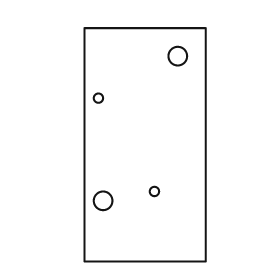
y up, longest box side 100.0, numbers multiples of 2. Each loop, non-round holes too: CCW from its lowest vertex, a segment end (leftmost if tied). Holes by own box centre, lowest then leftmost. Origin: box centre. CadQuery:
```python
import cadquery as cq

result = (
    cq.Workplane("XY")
    .moveTo(-26.0, -50.0)
    .lineTo(26.0, -50.0)
    .lineTo(26.0, 50.0)
    .lineTo(-26.0, 50.0)
    .close()
    .moveTo(-18.0, -24.0)
    .circle(4.0)
    .moveTo(4.0, -20.0)
    .circle(2.0)
    .moveTo(-20.0, 20.0)
    .circle(2.0)
    .moveTo(14.0, 38.0)
    .circle(4.0)
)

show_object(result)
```